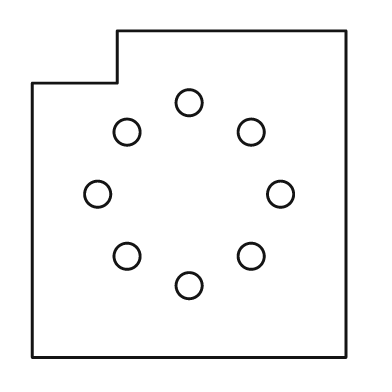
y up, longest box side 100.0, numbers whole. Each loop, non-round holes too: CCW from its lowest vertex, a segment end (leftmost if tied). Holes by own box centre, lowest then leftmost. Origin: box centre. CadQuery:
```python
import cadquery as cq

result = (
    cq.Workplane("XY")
    .moveTo(-48.0, -50.0)
    .lineTo(48.0, -50.0)
    .lineTo(48.0, 50.0)
    .lineTo(-22.0, 50.0)
    .lineTo(-22.0, 34.0)
    .lineTo(-48.0, 34.0)
    .close()
    .moveTo(0.0, -28.0)
    .circle(4.0)
    .moveTo(-19.0, -19.0)
    .circle(4.0)
    .moveTo(19.0, -19.0)
    .circle(4.0)
    .moveTo(-28.0, 0.0)
    .circle(4.0)
    .moveTo(28.0, 0.0)
    .circle(4.0)
    .moveTo(-19.0, 19.0)
    .circle(4.0)
    .moveTo(19.0, 19.0)
    .circle(4.0)
    .moveTo(0.0, 28.0)
    .circle(4.0)
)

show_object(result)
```